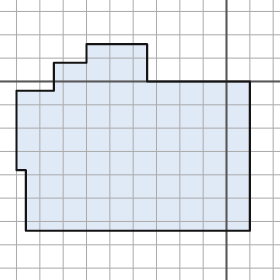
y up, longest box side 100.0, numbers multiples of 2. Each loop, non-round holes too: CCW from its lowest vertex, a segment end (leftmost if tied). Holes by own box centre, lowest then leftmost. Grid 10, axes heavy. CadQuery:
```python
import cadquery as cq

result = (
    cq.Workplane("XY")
    .moveTo(-86.0, -64.0)
    .lineTo(10.0, -64.0)
    .lineTo(10.0, 0.0)
    .lineTo(-34.0, 0.0)
    .lineTo(-34.0, 16.0)
    .lineTo(-60.0, 16.0)
    .lineTo(-60.0, 8.0)
    .lineTo(-74.0, 8.0)
    .lineTo(-74.0, -4.0)
    .lineTo(-90.0, -4.0)
    .lineTo(-90.0, -38.0)
    .lineTo(-86.0, -38.0)
    .close()
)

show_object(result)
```